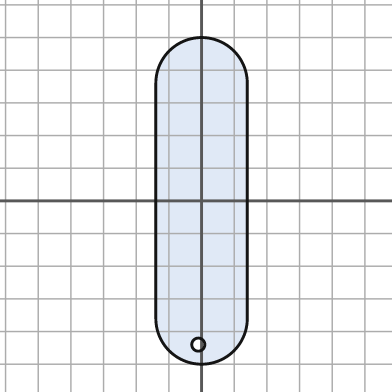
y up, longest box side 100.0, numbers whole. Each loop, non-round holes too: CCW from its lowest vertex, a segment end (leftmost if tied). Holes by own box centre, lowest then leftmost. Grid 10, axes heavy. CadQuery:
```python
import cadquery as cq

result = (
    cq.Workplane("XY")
    .moveTo(-14.0, -36.0)
    .threePointArc((0.0, -50.0), (14.0, -36.0))
    .lineTo(14.0, 36.0)
    .threePointArc((0.0, 50.0), (-14.0, 36.0))
    .close()
    .moveTo(-1.0, -44.0)
    .circle(2.0)
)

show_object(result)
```